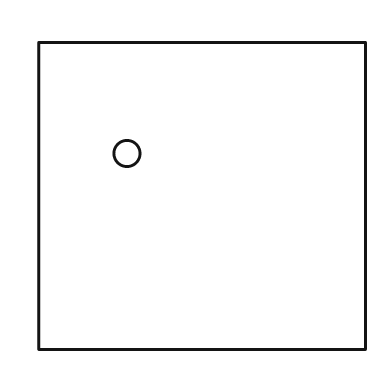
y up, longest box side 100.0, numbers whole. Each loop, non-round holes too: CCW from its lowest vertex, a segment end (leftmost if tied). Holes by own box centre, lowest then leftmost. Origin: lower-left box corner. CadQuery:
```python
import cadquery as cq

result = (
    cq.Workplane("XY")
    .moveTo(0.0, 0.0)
    .lineTo(100.0, 0.0)
    .lineTo(100.0, 94.0)
    .lineTo(0.0, 94.0)
    .close()
    .moveTo(27.0, 60.0)
    .circle(4.0)
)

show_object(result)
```